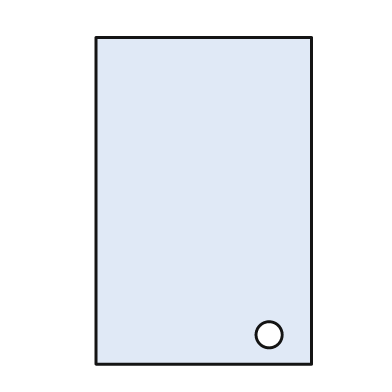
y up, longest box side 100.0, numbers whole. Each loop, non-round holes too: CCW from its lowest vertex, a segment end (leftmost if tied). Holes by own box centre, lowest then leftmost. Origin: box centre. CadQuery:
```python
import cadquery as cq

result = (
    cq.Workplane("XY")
    .moveTo(-33.0, -50.0)
    .lineTo(33.0, -50.0)
    .lineTo(33.0, 50.0)
    .lineTo(-33.0, 50.0)
    .close()
    .moveTo(20.0, -41.0)
    .circle(4.0)
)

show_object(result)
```